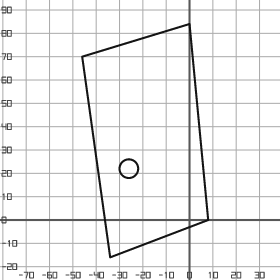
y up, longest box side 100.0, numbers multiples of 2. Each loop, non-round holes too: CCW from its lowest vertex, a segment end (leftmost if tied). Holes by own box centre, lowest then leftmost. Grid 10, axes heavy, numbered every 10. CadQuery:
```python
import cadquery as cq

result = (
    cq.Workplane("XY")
    .moveTo(-34.0, -16.0)
    .lineTo(8.0, 0.0)
    .lineTo(0.0, 84.0)
    .lineTo(-46.0, 70.0)
    .close()
    .moveTo(-26.0, 22.0)
    .circle(4.0)
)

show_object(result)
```